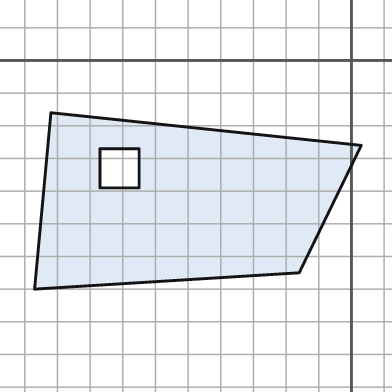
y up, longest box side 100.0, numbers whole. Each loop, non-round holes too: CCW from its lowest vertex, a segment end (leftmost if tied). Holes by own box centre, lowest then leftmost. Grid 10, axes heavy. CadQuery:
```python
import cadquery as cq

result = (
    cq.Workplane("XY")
    .moveTo(-97.0, -70.0)
    .lineTo(-16.0, -65.0)
    .lineTo(3.0, -26.0)
    .lineTo(-92.0, -16.0)
    .close()
    .moveTo(-77.0, -39.0)
    .lineTo(-65.0, -39.0)
    .lineTo(-65.0, -27.0)
    .lineTo(-77.0, -27.0)
    .close()
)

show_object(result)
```